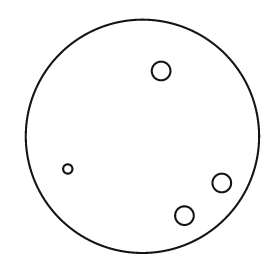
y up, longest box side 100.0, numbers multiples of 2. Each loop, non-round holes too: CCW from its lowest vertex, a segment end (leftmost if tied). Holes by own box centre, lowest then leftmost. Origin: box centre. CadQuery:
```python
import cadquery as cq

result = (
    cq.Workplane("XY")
    .moveTo(0.0, 0.0)
    .circle(50.0)
    .moveTo(18.0, -34.0)
    .circle(4.0)
    .moveTo(34.0, -20.0)
    .circle(4.0)
    .moveTo(-32.0, -14.0)
    .circle(2.0)
    .moveTo(8.0, 28.0)
    .circle(4.0)
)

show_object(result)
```